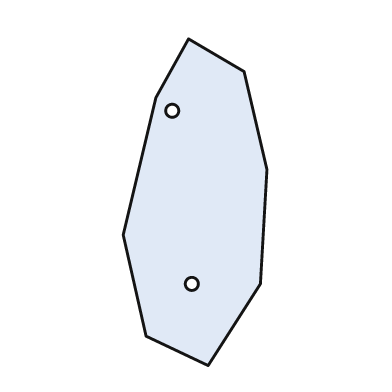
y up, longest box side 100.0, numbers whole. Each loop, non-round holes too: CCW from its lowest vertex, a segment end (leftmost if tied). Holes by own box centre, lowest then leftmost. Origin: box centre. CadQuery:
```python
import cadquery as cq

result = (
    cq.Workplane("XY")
    .moveTo(4.0, -50.0)
    .lineTo(20.0, -25.0)
    .lineTo(22.0, 10.0)
    .lineTo(15.0, 40.0)
    .lineTo(-2.0, 50.0)
    .lineTo(-12.0, 32.0)
    .lineTo(-22.0, -10.0)
    .lineTo(-15.0, -41.0)
    .close()
    .moveTo(-1.0, -25.0)
    .circle(2.0)
    .moveTo(-7.0, 28.0)
    .circle(2.0)
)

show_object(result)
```